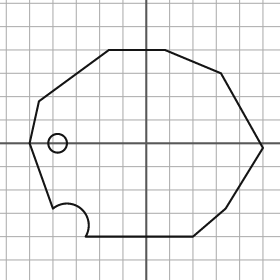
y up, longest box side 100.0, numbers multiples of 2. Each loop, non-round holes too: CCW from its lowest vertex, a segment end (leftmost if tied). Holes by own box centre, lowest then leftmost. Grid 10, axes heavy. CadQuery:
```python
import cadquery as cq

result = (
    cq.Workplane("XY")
    .moveTo(-26.0, -40.0)
    .lineTo(20.0, -40.0)
    .lineTo(34.0, -28.0)
    .lineTo(50.0, -2.0)
    .lineTo(32.0, 30.0)
    .lineTo(8.0, 40.0)
    .lineTo(-16.0, 40.0)
    .lineTo(-46.0, 18.0)
    .lineTo(-50.0, 0.0)
    .lineTo(-40.0, -28.0)
    .threePointArc((-28.0, -28.0), (-26.0, -40.0))
    .close()
    .moveTo(-38.0, 0.0)
    .circle(4.0)
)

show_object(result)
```